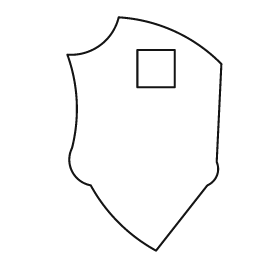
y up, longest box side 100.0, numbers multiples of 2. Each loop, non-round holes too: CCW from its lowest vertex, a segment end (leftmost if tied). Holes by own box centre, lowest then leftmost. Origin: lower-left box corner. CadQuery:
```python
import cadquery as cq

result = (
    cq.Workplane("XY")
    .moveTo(38.0, 0.0)
    .lineTo(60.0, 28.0)
    .threePointArc((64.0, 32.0), (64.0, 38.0))
    .lineTo(66.0, 80.0)
    .threePointArc((46.0, 94.0), (22.0, 100.0))
    .threePointArc((14.0, 88.0), (0.0, 84.0))
    .threePointArc((4.0, 64.0), (2.0, 44.0))
    .threePointArc((2.0, 34.0), (10.0, 28.0))
    .threePointArc((22.0, 12.0), (38.0, 0.0))
    .close()
    .moveTo(30.0, 70.0)
    .lineTo(46.0, 70.0)
    .lineTo(46.0, 86.0)
    .lineTo(30.0, 86.0)
    .close()
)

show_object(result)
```